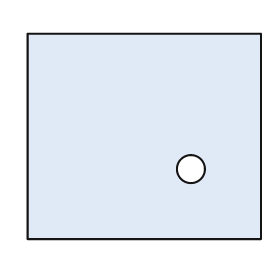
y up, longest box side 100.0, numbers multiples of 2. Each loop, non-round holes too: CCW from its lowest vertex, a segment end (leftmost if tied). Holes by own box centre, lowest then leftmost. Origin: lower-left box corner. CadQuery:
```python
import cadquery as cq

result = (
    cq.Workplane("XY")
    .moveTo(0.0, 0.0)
    .lineTo(100.0, 0.0)
    .lineTo(100.0, 88.0)
    .lineTo(0.0, 88.0)
    .close()
    .moveTo(70.0, 30.0)
    .circle(6.0)
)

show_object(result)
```